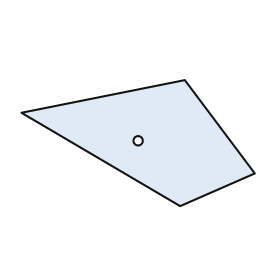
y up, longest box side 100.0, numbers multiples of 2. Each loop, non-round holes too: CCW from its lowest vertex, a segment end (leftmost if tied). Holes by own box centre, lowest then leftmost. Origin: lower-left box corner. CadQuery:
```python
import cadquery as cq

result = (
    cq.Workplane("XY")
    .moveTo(68.0, 0.0)
    .lineTo(100.0, 14.0)
    .lineTo(70.0, 54.0)
    .lineTo(0.0, 40.0)
    .close()
    .moveTo(50.0, 28.0)
    .circle(2.0)
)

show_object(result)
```